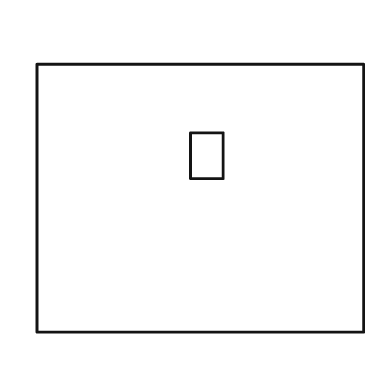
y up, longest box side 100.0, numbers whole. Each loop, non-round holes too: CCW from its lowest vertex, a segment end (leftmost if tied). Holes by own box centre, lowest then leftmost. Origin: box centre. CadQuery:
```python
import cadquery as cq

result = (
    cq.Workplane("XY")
    .moveTo(-50.0, -41.0)
    .lineTo(50.0, -41.0)
    .lineTo(50.0, 41.0)
    .lineTo(-50.0, 41.0)
    .close()
    .moveTo(-3.0, 6.0)
    .lineTo(7.0, 6.0)
    .lineTo(7.0, 20.0)
    .lineTo(-3.0, 20.0)
    .close()
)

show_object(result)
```